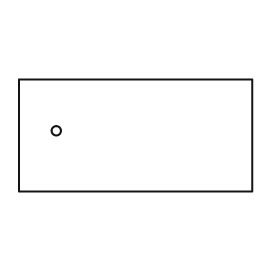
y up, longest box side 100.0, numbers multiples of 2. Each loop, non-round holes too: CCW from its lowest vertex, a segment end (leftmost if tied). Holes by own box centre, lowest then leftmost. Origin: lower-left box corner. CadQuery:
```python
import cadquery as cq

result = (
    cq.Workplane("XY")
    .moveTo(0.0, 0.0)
    .lineTo(100.0, 0.0)
    .lineTo(100.0, 48.0)
    .lineTo(0.0, 48.0)
    .close()
    .moveTo(16.0, 26.0)
    .circle(2.0)
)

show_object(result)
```